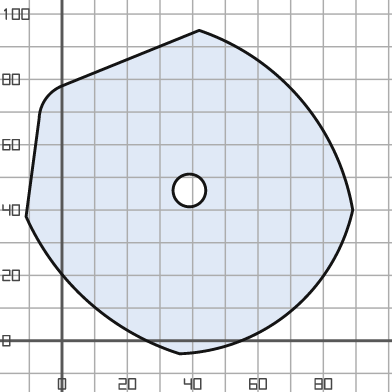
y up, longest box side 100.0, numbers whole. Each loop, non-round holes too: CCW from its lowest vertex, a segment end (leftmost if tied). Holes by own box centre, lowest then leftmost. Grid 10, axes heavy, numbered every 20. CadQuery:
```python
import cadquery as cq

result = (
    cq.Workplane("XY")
    .moveTo(36.0, -4.0)
    .threePointArc((70.0, 9.0), (89.0, 40.0))
    .threePointArc((73.0, 74.0), (42.0, 95.0))
    .lineTo(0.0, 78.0)
    .threePointArc((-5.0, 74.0), (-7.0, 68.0))
    .lineTo(-11.0, 38.0)
    .threePointArc((8.0, 12.0), (36.0, -4.0))
    .close()
    .moveTo(39.0, 46.0)
    .circle(5.0)
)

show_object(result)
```